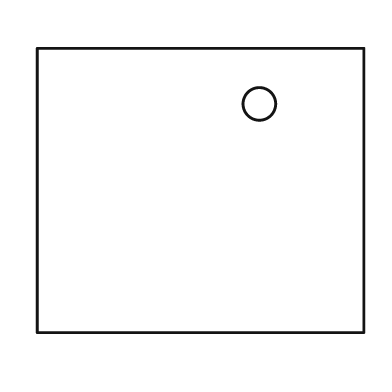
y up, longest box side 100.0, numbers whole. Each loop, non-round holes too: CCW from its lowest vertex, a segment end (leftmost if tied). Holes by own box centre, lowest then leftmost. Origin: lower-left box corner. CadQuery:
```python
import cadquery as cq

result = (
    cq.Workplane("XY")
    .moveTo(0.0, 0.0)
    .lineTo(100.0, 0.0)
    .lineTo(100.0, 87.0)
    .lineTo(0.0, 87.0)
    .close()
    .moveTo(68.0, 70.0)
    .circle(5.0)
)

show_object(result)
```